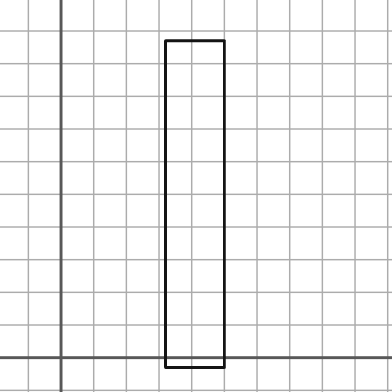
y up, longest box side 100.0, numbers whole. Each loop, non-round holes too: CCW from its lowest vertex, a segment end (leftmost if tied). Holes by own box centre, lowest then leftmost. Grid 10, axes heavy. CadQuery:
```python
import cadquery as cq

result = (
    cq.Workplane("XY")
    .moveTo(32.0, -3.0)
    .lineTo(50.0, -3.0)
    .lineTo(50.0, 97.0)
    .lineTo(32.0, 97.0)
    .close()
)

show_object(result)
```